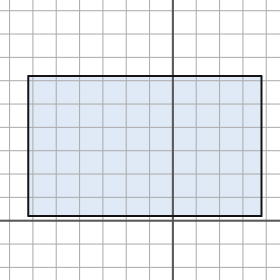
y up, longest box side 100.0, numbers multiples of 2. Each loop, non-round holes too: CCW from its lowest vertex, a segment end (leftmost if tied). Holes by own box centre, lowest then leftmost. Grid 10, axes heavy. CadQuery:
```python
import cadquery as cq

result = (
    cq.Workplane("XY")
    .moveTo(-62.0, 2.0)
    .lineTo(38.0, 2.0)
    .lineTo(38.0, 62.0)
    .lineTo(-62.0, 62.0)
    .close()
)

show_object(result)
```